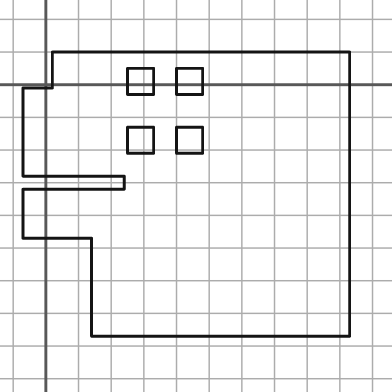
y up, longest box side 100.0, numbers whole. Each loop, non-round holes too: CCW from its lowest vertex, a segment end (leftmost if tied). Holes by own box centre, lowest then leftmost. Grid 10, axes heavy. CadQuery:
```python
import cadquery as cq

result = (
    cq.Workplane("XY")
    .moveTo(14.0, -77.0)
    .lineTo(93.0, -77.0)
    .lineTo(93.0, 10.0)
    .lineTo(2.0, 10.0)
    .lineTo(2.0, -1.0)
    .lineTo(-7.0, -1.0)
    .lineTo(-7.0, -28.0)
    .lineTo(24.0, -28.0)
    .lineTo(24.0, -32.0)
    .lineTo(-7.0, -32.0)
    .lineTo(-7.0, -47.0)
    .lineTo(14.0, -47.0)
    .close()
    .moveTo(25.0, -21.0)
    .lineTo(33.0, -21.0)
    .lineTo(33.0, -13.0)
    .lineTo(25.0, -13.0)
    .close()
    .moveTo(40.0, -21.0)
    .lineTo(48.0, -21.0)
    .lineTo(48.0, -13.0)
    .lineTo(40.0, -13.0)
    .close()
    .moveTo(25.0, -3.0)
    .lineTo(33.0, -3.0)
    .lineTo(33.0, 5.0)
    .lineTo(25.0, 5.0)
    .close()
    .moveTo(40.0, -3.0)
    .lineTo(48.0, -3.0)
    .lineTo(48.0, 5.0)
    .lineTo(40.0, 5.0)
    .close()
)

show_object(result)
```